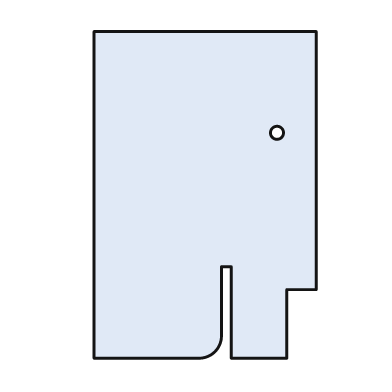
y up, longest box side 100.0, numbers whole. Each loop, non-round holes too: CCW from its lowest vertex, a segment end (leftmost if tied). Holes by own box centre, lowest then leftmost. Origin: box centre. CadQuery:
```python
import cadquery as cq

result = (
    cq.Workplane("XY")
    .moveTo(-34.0, -50.0)
    .lineTo(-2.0, -50.0)
    .threePointArc((3.0, -48.0), (5.0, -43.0))
    .lineTo(5.0, -22.0)
    .lineTo(8.0, -22.0)
    .lineTo(8.0, -50.0)
    .lineTo(25.0, -50.0)
    .lineTo(25.0, -29.0)
    .lineTo(34.0, -29.0)
    .lineTo(34.0, 50.0)
    .lineTo(-34.0, 50.0)
    .close()
    .moveTo(22.0, 19.0)
    .circle(2.0)
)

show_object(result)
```